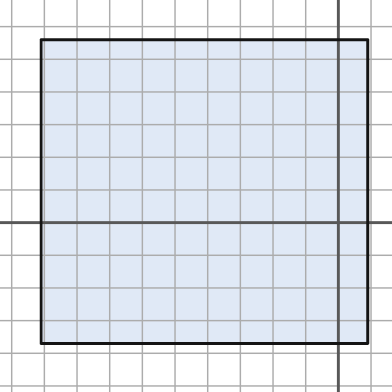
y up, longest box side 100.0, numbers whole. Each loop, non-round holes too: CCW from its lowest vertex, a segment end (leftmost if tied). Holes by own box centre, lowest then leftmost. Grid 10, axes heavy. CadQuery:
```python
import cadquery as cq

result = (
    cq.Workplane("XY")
    .moveTo(-91.0, -37.0)
    .lineTo(9.0, -37.0)
    .lineTo(9.0, 56.0)
    .lineTo(-91.0, 56.0)
    .close()
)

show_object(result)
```